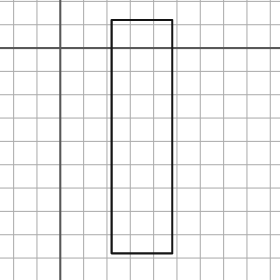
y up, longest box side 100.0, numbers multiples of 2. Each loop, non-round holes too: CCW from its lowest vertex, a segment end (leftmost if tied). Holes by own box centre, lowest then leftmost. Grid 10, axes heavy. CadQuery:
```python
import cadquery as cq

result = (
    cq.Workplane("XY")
    .moveTo(22.0, -88.0)
    .lineTo(48.0, -88.0)
    .lineTo(48.0, 12.0)
    .lineTo(22.0, 12.0)
    .close()
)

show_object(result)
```